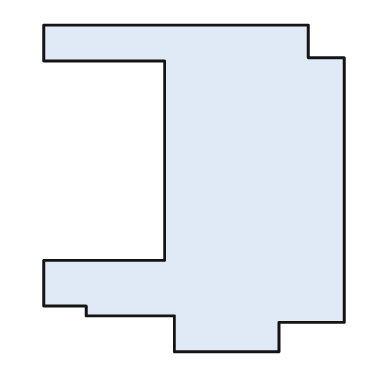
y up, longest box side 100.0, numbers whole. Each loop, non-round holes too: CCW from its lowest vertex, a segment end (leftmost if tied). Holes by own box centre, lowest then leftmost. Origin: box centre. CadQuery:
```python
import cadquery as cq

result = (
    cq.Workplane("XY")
    .moveTo(-6.0, -50.0)
    .lineTo(26.0, -50.0)
    .lineTo(26.0, -41.0)
    .lineTo(46.0, -41.0)
    .lineTo(46.0, 40.0)
    .lineTo(35.0, 40.0)
    .lineTo(35.0, 50.0)
    .lineTo(-46.0, 50.0)
    .lineTo(-46.0, 39.0)
    .lineTo(-9.0, 39.0)
    .lineTo(-9.0, -22.0)
    .lineTo(-46.0, -22.0)
    .lineTo(-46.0, -36.0)
    .lineTo(-33.0, -36.0)
    .lineTo(-33.0, -39.0)
    .lineTo(-6.0, -39.0)
    .close()
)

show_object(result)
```